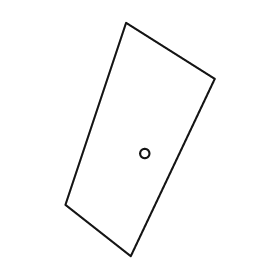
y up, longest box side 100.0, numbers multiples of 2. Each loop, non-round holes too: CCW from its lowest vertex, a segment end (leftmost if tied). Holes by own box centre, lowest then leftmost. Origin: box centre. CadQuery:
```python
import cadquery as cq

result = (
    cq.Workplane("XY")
    .moveTo(-4.0, -50.0)
    .lineTo(32.0, 26.0)
    .lineTo(-6.0, 50.0)
    .lineTo(-32.0, -28.0)
    .close()
    .moveTo(2.0, -6.0)
    .circle(2.0)
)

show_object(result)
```